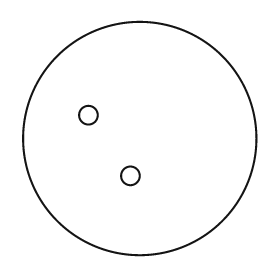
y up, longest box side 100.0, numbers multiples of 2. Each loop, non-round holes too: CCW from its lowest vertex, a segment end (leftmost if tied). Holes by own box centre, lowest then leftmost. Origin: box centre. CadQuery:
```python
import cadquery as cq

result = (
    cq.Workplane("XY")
    .moveTo(0.0, 0.0)
    .circle(50.0)
    .moveTo(-4.0, -16.0)
    .circle(4.0)
    .moveTo(-22.0, 10.0)
    .circle(4.0)
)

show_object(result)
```